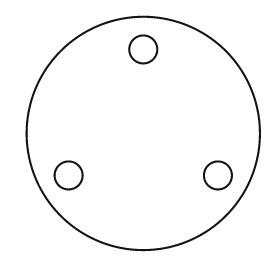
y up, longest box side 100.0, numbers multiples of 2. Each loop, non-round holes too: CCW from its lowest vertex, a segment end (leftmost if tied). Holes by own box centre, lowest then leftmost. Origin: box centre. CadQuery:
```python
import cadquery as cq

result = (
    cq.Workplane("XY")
    .moveTo(0.0, 0.0)
    .circle(50.0)
    .moveTo(-32.0, -18.0)
    .circle(6.0)
    .moveTo(32.0, -18.0)
    .circle(6.0)
    .moveTo(0.0, 36.0)
    .circle(6.0)
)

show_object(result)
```